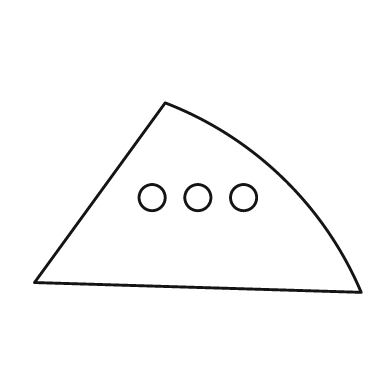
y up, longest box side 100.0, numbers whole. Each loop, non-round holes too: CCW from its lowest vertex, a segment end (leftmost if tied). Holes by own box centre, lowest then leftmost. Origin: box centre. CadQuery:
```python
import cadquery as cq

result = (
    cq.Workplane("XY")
    .moveTo(50.0, -29.0)
    .threePointArc((26.0, 6.0), (-10.0, 29.0))
    .lineTo(-50.0, -26.0)
    .close()
    .moveTo(-14.0, 0.0)
    .circle(4.0)
    .moveTo(0.0, 0.0)
    .circle(4.0)
    .moveTo(14.0, 0.0)
    .circle(4.0)
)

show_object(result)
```